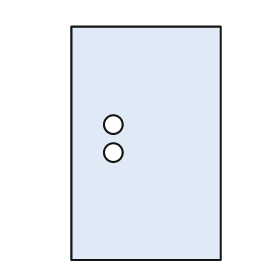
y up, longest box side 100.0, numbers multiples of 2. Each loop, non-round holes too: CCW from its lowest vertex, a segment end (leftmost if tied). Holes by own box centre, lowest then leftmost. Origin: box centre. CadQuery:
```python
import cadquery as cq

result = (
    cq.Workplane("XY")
    .moveTo(-32.0, -50.0)
    .lineTo(32.0, -50.0)
    .lineTo(32.0, 50.0)
    .lineTo(-32.0, 50.0)
    .close()
    .moveTo(-14.0, -4.0)
    .circle(4.0)
    .moveTo(-14.0, 8.0)
    .circle(4.0)
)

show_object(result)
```